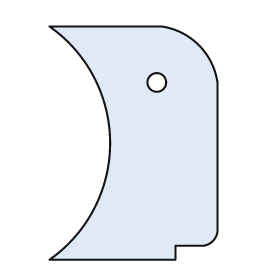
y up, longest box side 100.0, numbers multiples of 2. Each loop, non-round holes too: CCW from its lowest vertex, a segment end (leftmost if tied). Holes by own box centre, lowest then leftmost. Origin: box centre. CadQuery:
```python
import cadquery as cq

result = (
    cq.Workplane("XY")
    .moveTo(-36.0, -50.0)
    .lineTo(18.0, -50.0)
    .lineTo(18.0, -44.0)
    .lineTo(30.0, -44.0)
    .threePointArc((34.0, -42.0), (36.0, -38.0))
    .lineTo(36.0, 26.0)
    .threePointArc((28.0, 42.0), (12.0, 50.0))
    .lineTo(-36.0, 50.0)
    .threePointArc((-10.0, 0.0), (-36.0, -50.0))
    .close()
    .moveTo(10.0, 26.0)
    .circle(4.0)
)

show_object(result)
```